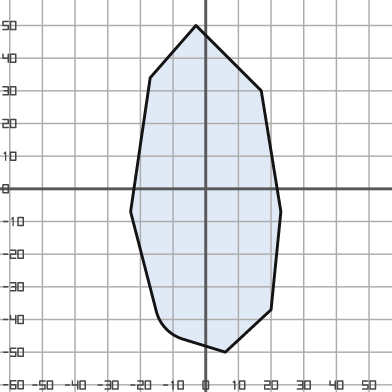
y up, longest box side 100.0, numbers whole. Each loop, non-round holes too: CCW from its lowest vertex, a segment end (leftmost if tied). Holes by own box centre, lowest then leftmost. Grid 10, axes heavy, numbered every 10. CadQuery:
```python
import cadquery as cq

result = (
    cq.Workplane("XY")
    .moveTo(6.0, -50.0)
    .lineTo(20.0, -37.0)
    .lineTo(23.0, -7.0)
    .lineTo(17.0, 30.0)
    .lineTo(-3.0, 50.0)
    .lineTo(-17.0, 34.0)
    .lineTo(-23.0, -7.0)
    .lineTo(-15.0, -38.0)
    .threePointArc((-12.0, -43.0), (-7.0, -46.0))
    .close()
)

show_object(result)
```